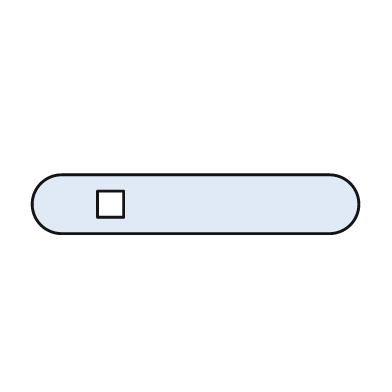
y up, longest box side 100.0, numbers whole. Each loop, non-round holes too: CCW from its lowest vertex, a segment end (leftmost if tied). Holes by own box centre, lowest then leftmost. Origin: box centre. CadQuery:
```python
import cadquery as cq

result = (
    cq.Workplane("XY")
    .moveTo(-41.0, -9.0)
    .lineTo(41.0, -9.0)
    .threePointArc((50.0, 0.0), (41.0, 9.0))
    .lineTo(-41.0, 9.0)
    .threePointArc((-50.0, 0.0), (-41.0, -9.0))
    .close()
    .moveTo(-30.0, -4.0)
    .lineTo(-22.0, -4.0)
    .lineTo(-22.0, 4.0)
    .lineTo(-30.0, 4.0)
    .close()
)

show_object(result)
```